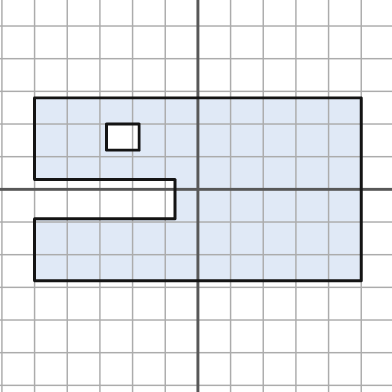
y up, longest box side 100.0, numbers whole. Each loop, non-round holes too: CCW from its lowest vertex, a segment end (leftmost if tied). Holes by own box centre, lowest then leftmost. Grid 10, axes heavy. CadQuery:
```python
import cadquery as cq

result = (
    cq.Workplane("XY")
    .moveTo(-50.0, -28.0)
    .lineTo(50.0, -28.0)
    .lineTo(50.0, 28.0)
    .lineTo(-50.0, 28.0)
    .lineTo(-50.0, 3.0)
    .lineTo(-7.0, 3.0)
    .lineTo(-7.0, -9.0)
    .lineTo(-50.0, -9.0)
    .close()
    .moveTo(-28.0, 12.0)
    .lineTo(-18.0, 12.0)
    .lineTo(-18.0, 20.0)
    .lineTo(-28.0, 20.0)
    .close()
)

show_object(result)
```